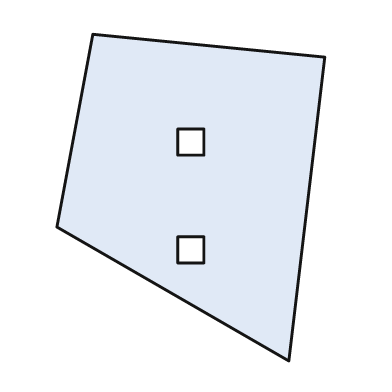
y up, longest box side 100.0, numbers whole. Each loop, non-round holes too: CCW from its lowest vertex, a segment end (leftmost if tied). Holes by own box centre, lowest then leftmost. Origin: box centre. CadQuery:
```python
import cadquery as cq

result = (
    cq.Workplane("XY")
    .moveTo(30.0, -50.0)
    .lineTo(41.0, 43.0)
    .lineTo(-30.0, 50.0)
    .lineTo(-41.0, -9.0)
    .close()
    .moveTo(-4.0, -20.0)
    .lineTo(4.0, -20.0)
    .lineTo(4.0, -12.0)
    .lineTo(-4.0, -12.0)
    .close()
    .moveTo(-4.0, 13.0)
    .lineTo(4.0, 13.0)
    .lineTo(4.0, 21.0)
    .lineTo(-4.0, 21.0)
    .close()
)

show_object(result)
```